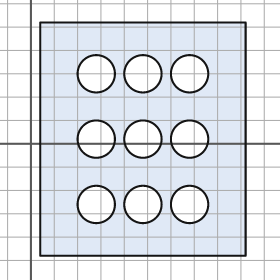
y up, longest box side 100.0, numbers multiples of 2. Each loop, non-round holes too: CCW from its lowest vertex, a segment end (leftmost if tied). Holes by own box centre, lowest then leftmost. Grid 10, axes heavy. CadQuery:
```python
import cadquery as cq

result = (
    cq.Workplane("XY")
    .moveTo(4.0, -48.0)
    .lineTo(92.0, -48.0)
    .lineTo(92.0, 52.0)
    .lineTo(4.0, 52.0)
    .close()
    .moveTo(28.0, -26.0)
    .circle(8.0)
    .moveTo(48.0, -26.0)
    .circle(8.0)
    .moveTo(68.0, -26.0)
    .circle(8.0)
    .moveTo(28.0, 2.0)
    .circle(8.0)
    .moveTo(48.0, 2.0)
    .circle(8.0)
    .moveTo(68.0, 2.0)
    .circle(8.0)
    .moveTo(28.0, 30.0)
    .circle(8.0)
    .moveTo(48.0, 30.0)
    .circle(8.0)
    .moveTo(68.0, 30.0)
    .circle(8.0)
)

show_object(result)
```